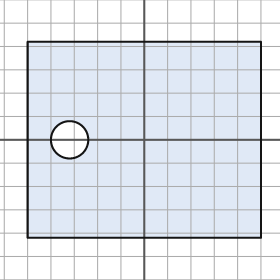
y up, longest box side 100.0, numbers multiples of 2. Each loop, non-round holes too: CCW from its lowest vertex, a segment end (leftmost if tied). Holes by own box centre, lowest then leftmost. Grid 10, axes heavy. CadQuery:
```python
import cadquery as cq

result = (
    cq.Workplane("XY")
    .moveTo(-50.0, -42.0)
    .lineTo(50.0, -42.0)
    .lineTo(50.0, 42.0)
    .lineTo(-50.0, 42.0)
    .close()
    .moveTo(-32.0, 0.0)
    .circle(8.0)
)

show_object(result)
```